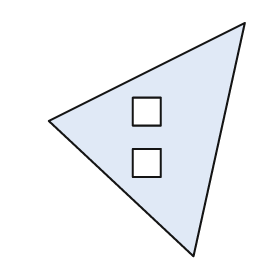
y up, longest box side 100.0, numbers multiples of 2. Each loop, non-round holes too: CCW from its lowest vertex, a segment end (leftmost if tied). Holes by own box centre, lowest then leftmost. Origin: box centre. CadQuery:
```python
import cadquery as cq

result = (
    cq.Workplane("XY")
    .moveTo(20.0, -50.0)
    .lineTo(42.0, 50.0)
    .lineTo(-42.0, 8.0)
    .close()
    .moveTo(-6.0, -16.0)
    .lineTo(6.0, -16.0)
    .lineTo(6.0, -4.0)
    .lineTo(-6.0, -4.0)
    .close()
    .moveTo(-6.0, 6.0)
    .lineTo(6.0, 6.0)
    .lineTo(6.0, 18.0)
    .lineTo(-6.0, 18.0)
    .close()
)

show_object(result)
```